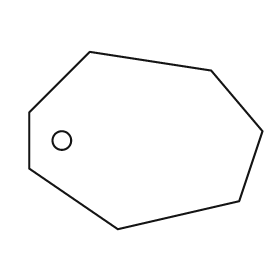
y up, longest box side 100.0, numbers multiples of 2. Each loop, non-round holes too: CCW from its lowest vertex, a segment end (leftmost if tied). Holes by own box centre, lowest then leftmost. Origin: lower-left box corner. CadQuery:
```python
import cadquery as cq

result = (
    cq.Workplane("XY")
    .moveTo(38.0, 0.0)
    .lineTo(90.0, 12.0)
    .lineTo(100.0, 42.0)
    .lineTo(78.0, 68.0)
    .lineTo(26.0, 76.0)
    .lineTo(0.0, 50.0)
    .lineTo(0.0, 26.0)
    .close()
    .moveTo(14.0, 38.0)
    .circle(4.0)
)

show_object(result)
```